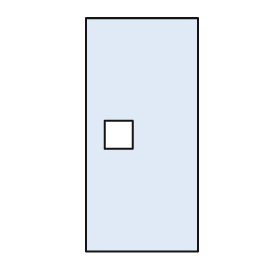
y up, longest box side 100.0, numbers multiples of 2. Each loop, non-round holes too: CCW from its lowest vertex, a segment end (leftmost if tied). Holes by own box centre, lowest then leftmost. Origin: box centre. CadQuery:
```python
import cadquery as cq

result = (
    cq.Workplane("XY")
    .moveTo(-24.0, -50.0)
    .lineTo(24.0, -50.0)
    .lineTo(24.0, 50.0)
    .lineTo(-24.0, 50.0)
    .close()
    .moveTo(-16.0, -6.0)
    .lineTo(-4.0, -6.0)
    .lineTo(-4.0, 6.0)
    .lineTo(-16.0, 6.0)
    .close()
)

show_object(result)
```